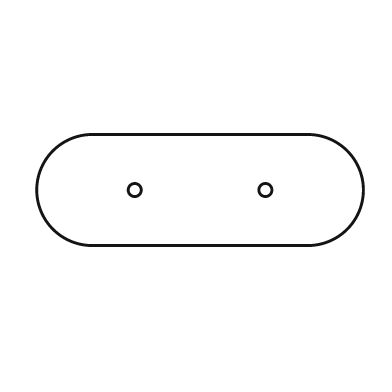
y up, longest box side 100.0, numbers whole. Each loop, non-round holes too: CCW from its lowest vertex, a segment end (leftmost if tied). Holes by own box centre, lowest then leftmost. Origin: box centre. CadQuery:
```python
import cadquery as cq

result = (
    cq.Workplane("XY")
    .moveTo(-33.0, -17.0)
    .lineTo(33.0, -17.0)
    .threePointArc((50.0, 0.0), (33.0, 17.0))
    .lineTo(-33.0, 17.0)
    .threePointArc((-50.0, 0.0), (-33.0, -17.0))
    .close()
    .moveTo(-20.0, 0.0)
    .circle(2.0)
    .moveTo(20.0, 0.0)
    .circle(2.0)
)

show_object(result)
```